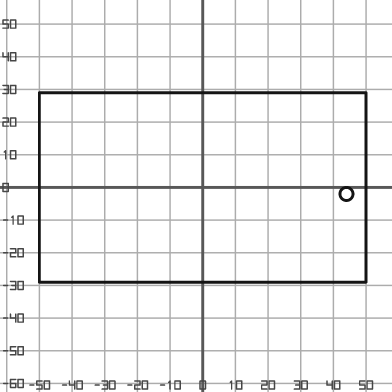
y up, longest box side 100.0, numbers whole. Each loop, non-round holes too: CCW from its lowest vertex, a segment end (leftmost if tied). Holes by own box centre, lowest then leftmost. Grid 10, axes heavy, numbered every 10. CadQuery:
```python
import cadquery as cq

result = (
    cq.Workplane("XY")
    .moveTo(-50.0, -29.0)
    .lineTo(50.0, -29.0)
    .lineTo(50.0, 29.0)
    .lineTo(-50.0, 29.0)
    .close()
    .moveTo(44.0, -2.0)
    .circle(2.0)
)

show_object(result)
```